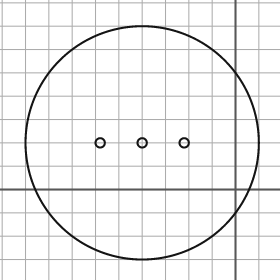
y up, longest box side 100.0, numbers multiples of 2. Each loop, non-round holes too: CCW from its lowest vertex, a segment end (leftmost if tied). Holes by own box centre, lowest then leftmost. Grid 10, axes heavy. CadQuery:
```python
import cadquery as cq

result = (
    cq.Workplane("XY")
    .moveTo(-40.0, 20.0)
    .circle(50.0)
    .moveTo(-58.0, 20.0)
    .circle(2.0)
    .moveTo(-40.0, 20.0)
    .circle(2.0)
    .moveTo(-22.0, 20.0)
    .circle(2.0)
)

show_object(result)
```